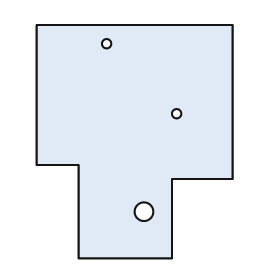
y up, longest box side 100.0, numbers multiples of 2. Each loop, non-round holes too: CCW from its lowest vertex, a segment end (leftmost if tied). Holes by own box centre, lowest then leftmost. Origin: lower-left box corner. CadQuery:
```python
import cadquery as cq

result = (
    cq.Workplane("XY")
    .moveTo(18.0, 0.0)
    .lineTo(58.0, 0.0)
    .lineTo(58.0, 34.0)
    .lineTo(84.0, 34.0)
    .lineTo(84.0, 100.0)
    .lineTo(0.0, 100.0)
    .lineTo(0.0, 40.0)
    .lineTo(18.0, 40.0)
    .close()
    .moveTo(46.0, 20.0)
    .circle(4.0)
    .moveTo(60.0, 62.0)
    .circle(2.0)
    .moveTo(30.0, 92.0)
    .circle(2.0)
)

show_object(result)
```